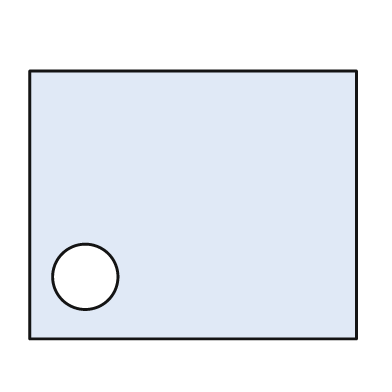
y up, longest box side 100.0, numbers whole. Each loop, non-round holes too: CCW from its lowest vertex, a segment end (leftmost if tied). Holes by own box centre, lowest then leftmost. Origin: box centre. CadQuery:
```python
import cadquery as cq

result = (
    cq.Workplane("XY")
    .moveTo(-50.0, -41.0)
    .lineTo(50.0, -41.0)
    .lineTo(50.0, 41.0)
    .lineTo(-50.0, 41.0)
    .close()
    .moveTo(-33.0, -22.0)
    .circle(10.0)
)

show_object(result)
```